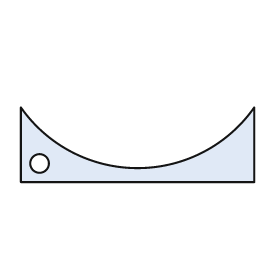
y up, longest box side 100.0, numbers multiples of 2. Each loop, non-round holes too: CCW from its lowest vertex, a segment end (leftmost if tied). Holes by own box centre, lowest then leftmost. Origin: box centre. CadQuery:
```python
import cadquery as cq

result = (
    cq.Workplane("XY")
    .moveTo(-50.0, -16.0)
    .lineTo(50.0, -16.0)
    .lineTo(50.0, 16.0)
    .threePointArc((0.0, -10.0), (-50.0, 16.0))
    .close()
    .moveTo(-42.0, -8.0)
    .circle(4.0)
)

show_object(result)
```